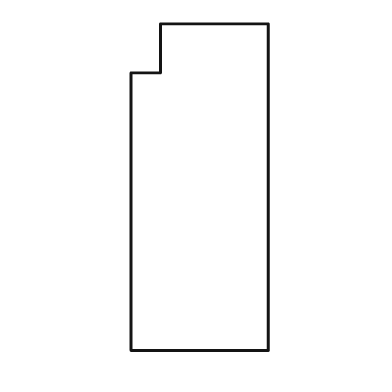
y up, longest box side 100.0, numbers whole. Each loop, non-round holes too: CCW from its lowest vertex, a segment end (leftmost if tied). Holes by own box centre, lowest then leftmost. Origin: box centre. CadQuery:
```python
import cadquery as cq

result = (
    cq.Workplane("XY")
    .moveTo(-21.0, -50.0)
    .lineTo(21.0, -50.0)
    .lineTo(21.0, 50.0)
    .lineTo(-12.0, 50.0)
    .lineTo(-12.0, 35.0)
    .lineTo(-21.0, 35.0)
    .close()
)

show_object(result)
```